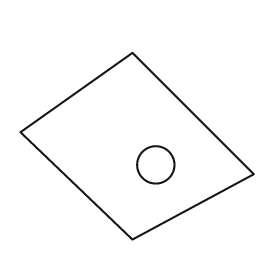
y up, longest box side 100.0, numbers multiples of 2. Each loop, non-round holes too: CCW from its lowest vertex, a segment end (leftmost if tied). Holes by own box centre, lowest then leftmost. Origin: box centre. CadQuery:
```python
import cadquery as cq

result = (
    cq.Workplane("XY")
    .moveTo(-2.0, -40.0)
    .lineTo(50.0, -12.0)
    .lineTo(-2.0, 40.0)
    .lineTo(-50.0, 6.0)
    .close()
    .moveTo(8.0, -8.0)
    .circle(8.0)
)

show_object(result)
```